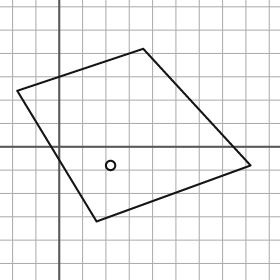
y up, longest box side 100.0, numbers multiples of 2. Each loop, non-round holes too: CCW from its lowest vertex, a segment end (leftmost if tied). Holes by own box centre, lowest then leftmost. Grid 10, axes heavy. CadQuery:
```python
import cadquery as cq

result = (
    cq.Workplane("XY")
    .moveTo(16.0, -32.0)
    .lineTo(82.0, -8.0)
    .lineTo(36.0, 42.0)
    .lineTo(-18.0, 24.0)
    .close()
    .moveTo(22.0, -8.0)
    .circle(2.0)
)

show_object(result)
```